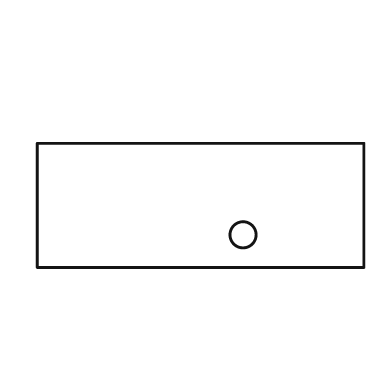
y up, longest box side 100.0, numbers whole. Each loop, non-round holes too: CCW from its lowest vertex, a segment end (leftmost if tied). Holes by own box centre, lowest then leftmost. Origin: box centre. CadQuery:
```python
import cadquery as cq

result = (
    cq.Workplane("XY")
    .moveTo(-50.0, -19.0)
    .lineTo(50.0, -19.0)
    .lineTo(50.0, 19.0)
    .lineTo(-50.0, 19.0)
    .close()
    .moveTo(13.0, -9.0)
    .circle(4.0)
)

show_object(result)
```